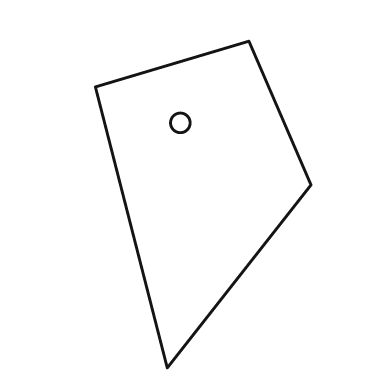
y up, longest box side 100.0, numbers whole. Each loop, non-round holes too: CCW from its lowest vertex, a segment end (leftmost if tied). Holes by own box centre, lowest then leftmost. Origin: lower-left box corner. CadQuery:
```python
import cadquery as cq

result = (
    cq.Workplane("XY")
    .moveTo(22.0, 0.0)
    .lineTo(66.0, 56.0)
    .lineTo(47.0, 100.0)
    .lineTo(0.0, 86.0)
    .close()
    .moveTo(26.0, 75.0)
    .circle(3.0)
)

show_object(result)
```